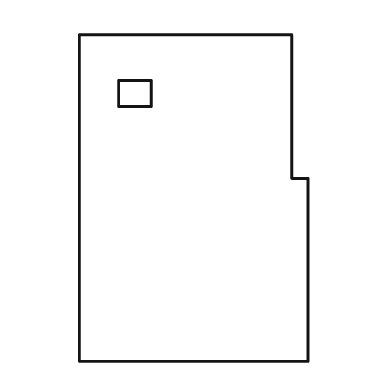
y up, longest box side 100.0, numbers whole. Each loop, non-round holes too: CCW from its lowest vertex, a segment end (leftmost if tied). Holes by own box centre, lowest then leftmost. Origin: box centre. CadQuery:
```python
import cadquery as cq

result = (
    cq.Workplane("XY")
    .moveTo(-35.0, -50.0)
    .lineTo(35.0, -50.0)
    .lineTo(35.0, 6.0)
    .lineTo(30.0, 6.0)
    .lineTo(30.0, 50.0)
    .lineTo(-35.0, 50.0)
    .close()
    .moveTo(-23.0, 28.0)
    .lineTo(-13.0, 28.0)
    .lineTo(-13.0, 36.0)
    .lineTo(-23.0, 36.0)
    .close()
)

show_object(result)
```